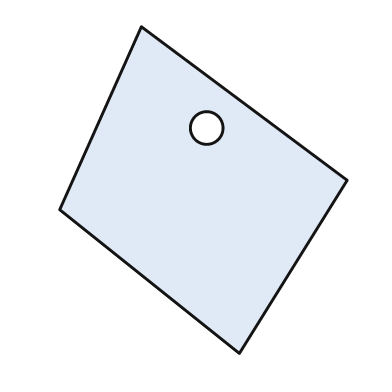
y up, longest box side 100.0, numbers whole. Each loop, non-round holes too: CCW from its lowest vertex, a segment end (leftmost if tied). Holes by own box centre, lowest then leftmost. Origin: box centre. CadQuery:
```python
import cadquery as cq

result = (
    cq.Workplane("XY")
    .moveTo(11.0, -50.0)
    .lineTo(44.0, 3.0)
    .lineTo(-19.0, 50.0)
    .lineTo(-44.0, -6.0)
    .close()
    .moveTo(1.0, 19.0)
    .circle(5.0)
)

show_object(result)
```